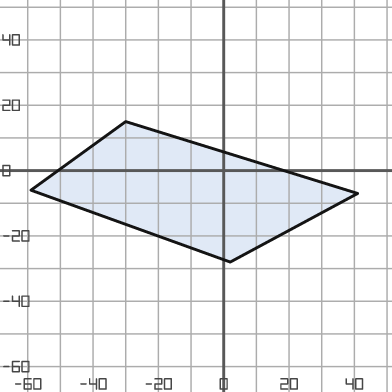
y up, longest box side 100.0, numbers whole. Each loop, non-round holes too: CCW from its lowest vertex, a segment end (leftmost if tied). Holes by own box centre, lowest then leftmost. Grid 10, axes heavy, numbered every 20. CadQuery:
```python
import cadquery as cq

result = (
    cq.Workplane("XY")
    .moveTo(2.0, -28.0)
    .lineTo(41.0, -7.0)
    .lineTo(-30.0, 15.0)
    .lineTo(-59.0, -6.0)
    .close()
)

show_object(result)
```